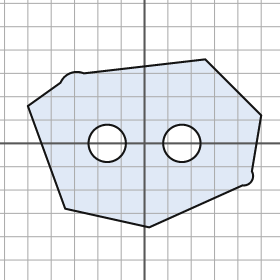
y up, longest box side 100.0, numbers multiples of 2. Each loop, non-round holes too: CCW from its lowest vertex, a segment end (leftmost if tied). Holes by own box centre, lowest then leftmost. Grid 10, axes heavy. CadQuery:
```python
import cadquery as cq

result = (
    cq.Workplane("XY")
    .moveTo(2.0, -36.0)
    .lineTo(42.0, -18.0)
    .threePointArc((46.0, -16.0), (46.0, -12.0))
    .lineTo(50.0, 12.0)
    .lineTo(26.0, 36.0)
    .lineTo(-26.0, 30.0)
    .threePointArc((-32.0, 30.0), (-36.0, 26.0))
    .lineTo(-50.0, 16.0)
    .lineTo(-34.0, -28.0)
    .close()
    .moveTo(-16.0, 0.0)
    .circle(8.0)
    .moveTo(16.0, 0.0)
    .circle(8.0)
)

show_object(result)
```